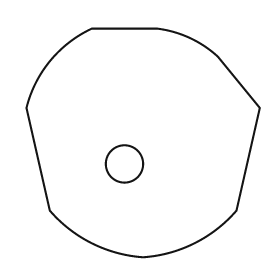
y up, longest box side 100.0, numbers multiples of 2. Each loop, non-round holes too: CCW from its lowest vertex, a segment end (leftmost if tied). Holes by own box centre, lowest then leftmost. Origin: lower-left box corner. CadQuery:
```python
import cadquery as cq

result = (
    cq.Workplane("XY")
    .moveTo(50.0, 0.0)
    .threePointArc((72.0, 6.0), (90.0, 20.0))
    .lineTo(100.0, 64.0)
    .lineTo(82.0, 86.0)
    .threePointArc((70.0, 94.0), (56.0, 98.0))
    .lineTo(28.0, 98.0)
    .threePointArc((10.0, 84.0), (0.0, 64.0))
    .lineTo(10.0, 20.0)
    .threePointArc((28.0, 6.0), (50.0, 0.0))
    .close()
    .moveTo(42.0, 40.0)
    .circle(8.0)
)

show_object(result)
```